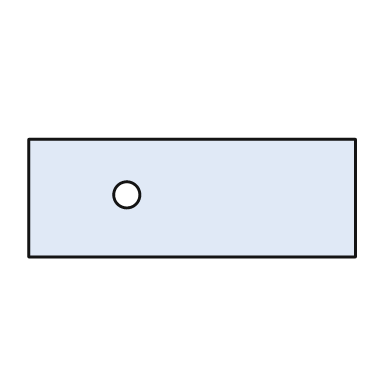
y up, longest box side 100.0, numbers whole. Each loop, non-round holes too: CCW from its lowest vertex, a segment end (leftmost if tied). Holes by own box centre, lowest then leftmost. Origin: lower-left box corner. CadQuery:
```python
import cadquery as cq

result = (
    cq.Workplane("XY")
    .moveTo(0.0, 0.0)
    .lineTo(100.0, 0.0)
    .lineTo(100.0, 36.0)
    .lineTo(0.0, 36.0)
    .close()
    .moveTo(30.0, 19.0)
    .circle(4.0)
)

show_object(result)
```